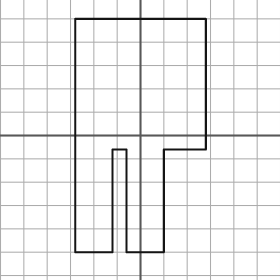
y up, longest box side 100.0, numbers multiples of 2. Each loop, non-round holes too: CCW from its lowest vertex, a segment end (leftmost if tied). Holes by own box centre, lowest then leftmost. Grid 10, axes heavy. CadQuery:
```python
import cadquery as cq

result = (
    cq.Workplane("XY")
    .moveTo(-28.0, -50.0)
    .lineTo(-12.0, -50.0)
    .lineTo(-12.0, -6.0)
    .lineTo(-6.0, -6.0)
    .lineTo(-6.0, -50.0)
    .lineTo(10.0, -50.0)
    .lineTo(10.0, -6.0)
    .lineTo(28.0, -6.0)
    .lineTo(28.0, 50.0)
    .lineTo(-28.0, 50.0)
    .close()
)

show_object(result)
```